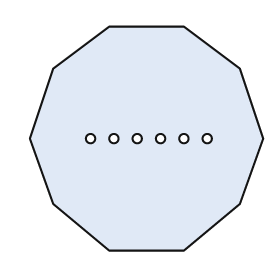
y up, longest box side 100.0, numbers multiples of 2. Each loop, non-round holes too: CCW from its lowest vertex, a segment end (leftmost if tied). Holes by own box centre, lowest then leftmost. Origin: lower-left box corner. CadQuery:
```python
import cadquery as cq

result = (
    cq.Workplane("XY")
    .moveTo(34.0, 0.0)
    .lineTo(66.0, 0.0)
    .lineTo(90.0, 20.0)
    .lineTo(100.0, 48.0)
    .lineTo(90.0, 78.0)
    .lineTo(66.0, 96.0)
    .lineTo(34.0, 96.0)
    .lineTo(10.0, 78.0)
    .lineTo(0.0, 48.0)
    .lineTo(10.0, 20.0)
    .close()
    .moveTo(26.0, 48.0)
    .circle(2.0)
    .moveTo(36.0, 48.0)
    .circle(2.0)
    .moveTo(46.0, 48.0)
    .circle(2.0)
    .moveTo(56.0, 48.0)
    .circle(2.0)
    .moveTo(66.0, 48.0)
    .circle(2.0)
    .moveTo(76.0, 48.0)
    .circle(2.0)
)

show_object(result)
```